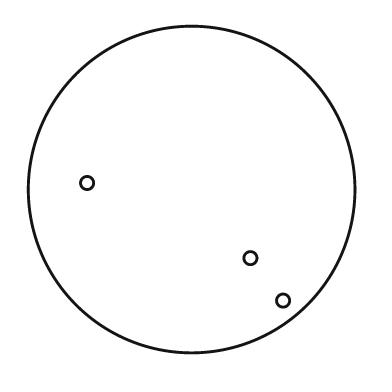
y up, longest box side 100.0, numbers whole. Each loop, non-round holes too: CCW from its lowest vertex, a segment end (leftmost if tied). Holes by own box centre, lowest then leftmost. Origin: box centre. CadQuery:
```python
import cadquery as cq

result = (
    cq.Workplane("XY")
    .moveTo(0.0, 0.0)
    .circle(50.0)
    .moveTo(28.0, -34.0)
    .circle(2.0)
    .moveTo(18.0, -21.0)
    .circle(2.0)
    .moveTo(-32.0, 2.0)
    .circle(2.0)
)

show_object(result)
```